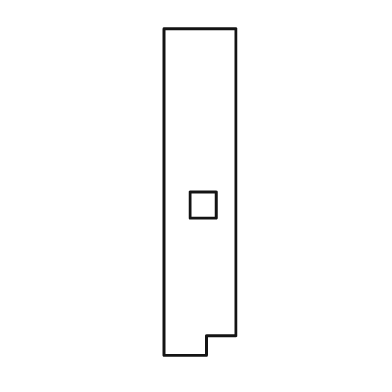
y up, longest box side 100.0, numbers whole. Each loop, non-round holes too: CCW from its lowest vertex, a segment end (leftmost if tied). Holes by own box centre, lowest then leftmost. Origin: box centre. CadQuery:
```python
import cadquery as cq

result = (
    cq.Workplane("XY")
    .moveTo(-11.0, -50.0)
    .lineTo(2.0, -50.0)
    .lineTo(2.0, -44.0)
    .lineTo(11.0, -44.0)
    .lineTo(11.0, 50.0)
    .lineTo(-11.0, 50.0)
    .close()
    .moveTo(-3.0, -8.0)
    .lineTo(5.0, -8.0)
    .lineTo(5.0, 0.0)
    .lineTo(-3.0, 0.0)
    .close()
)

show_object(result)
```